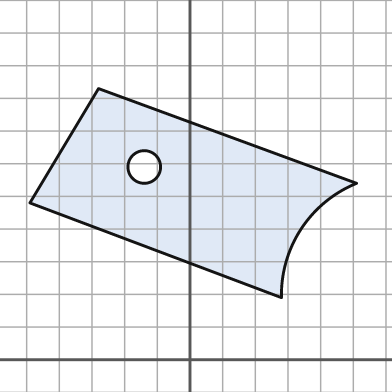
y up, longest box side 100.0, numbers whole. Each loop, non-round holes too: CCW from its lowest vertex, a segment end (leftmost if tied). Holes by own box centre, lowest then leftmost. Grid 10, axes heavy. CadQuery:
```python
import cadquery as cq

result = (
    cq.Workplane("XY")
    .moveTo(28.0, 19.0)
    .threePointArc((34.0, 40.0), (51.0, 54.0))
    .lineTo(-28.0, 83.0)
    .lineTo(-49.0, 48.0)
    .close()
    .moveTo(-14.0, 59.0)
    .circle(5.0)
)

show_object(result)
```